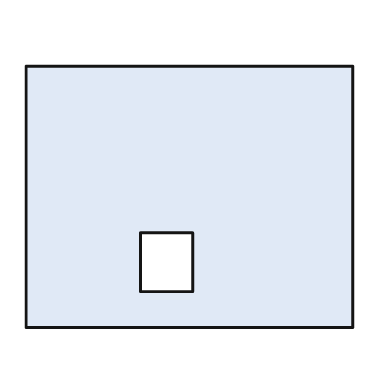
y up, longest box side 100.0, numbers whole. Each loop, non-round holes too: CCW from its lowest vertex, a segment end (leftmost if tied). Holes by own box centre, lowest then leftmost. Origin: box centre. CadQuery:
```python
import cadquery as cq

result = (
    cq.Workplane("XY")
    .moveTo(-50.0, -40.0)
    .lineTo(50.0, -40.0)
    .lineTo(50.0, 40.0)
    .lineTo(-50.0, 40.0)
    .close()
    .moveTo(-15.0, -29.0)
    .lineTo(1.0, -29.0)
    .lineTo(1.0, -11.0)
    .lineTo(-15.0, -11.0)
    .close()
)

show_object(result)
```